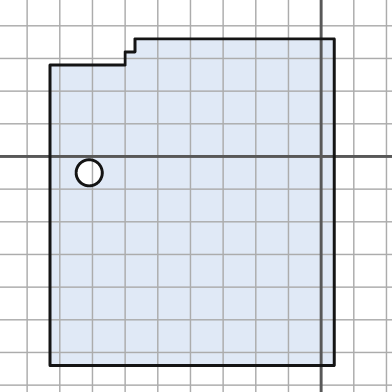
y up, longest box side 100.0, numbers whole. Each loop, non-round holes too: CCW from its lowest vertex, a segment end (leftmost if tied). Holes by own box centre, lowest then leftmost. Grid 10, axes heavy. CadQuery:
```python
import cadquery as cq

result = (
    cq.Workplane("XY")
    .moveTo(-83.0, -64.0)
    .lineTo(4.0, -64.0)
    .lineTo(4.0, 36.0)
    .lineTo(-57.0, 36.0)
    .lineTo(-57.0, 32.0)
    .lineTo(-60.0, 32.0)
    .lineTo(-60.0, 28.0)
    .lineTo(-83.0, 28.0)
    .close()
    .moveTo(-71.0, -5.0)
    .circle(4.0)
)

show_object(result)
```